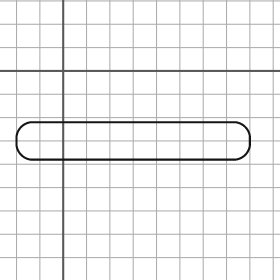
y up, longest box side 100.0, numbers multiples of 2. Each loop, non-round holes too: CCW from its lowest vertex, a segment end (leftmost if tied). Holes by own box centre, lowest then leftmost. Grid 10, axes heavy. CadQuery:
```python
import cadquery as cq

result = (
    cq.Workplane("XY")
    .moveTo(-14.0, -38.0)
    .lineTo(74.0, -38.0)
    .threePointArc((78.0, -36.0), (80.0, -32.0))
    .lineTo(80.0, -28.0)
    .threePointArc((78.0, -24.0), (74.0, -22.0))
    .lineTo(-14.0, -22.0)
    .threePointArc((-18.0, -24.0), (-20.0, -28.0))
    .lineTo(-20.0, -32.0)
    .threePointArc((-18.0, -36.0), (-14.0, -38.0))
    .close()
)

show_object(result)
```